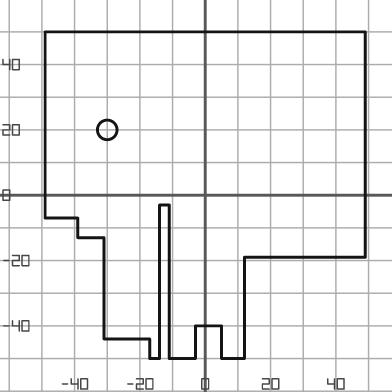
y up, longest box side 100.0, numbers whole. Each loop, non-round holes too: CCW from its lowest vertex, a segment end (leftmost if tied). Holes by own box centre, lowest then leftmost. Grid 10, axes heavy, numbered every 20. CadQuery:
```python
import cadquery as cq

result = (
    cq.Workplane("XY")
    .moveTo(-17.0, -50.0)
    .lineTo(-14.0, -50.0)
    .lineTo(-14.0, -3.0)
    .lineTo(-11.0, -3.0)
    .lineTo(-11.0, -50.0)
    .lineTo(-3.0, -50.0)
    .lineTo(-3.0, -40.0)
    .lineTo(5.0, -40.0)
    .lineTo(5.0, -50.0)
    .lineTo(12.0, -50.0)
    .lineTo(12.0, -19.0)
    .lineTo(49.0, -19.0)
    .lineTo(49.0, 50.0)
    .lineTo(-49.0, 50.0)
    .lineTo(-49.0, -7.0)
    .lineTo(-39.0, -7.0)
    .lineTo(-39.0, -13.0)
    .lineTo(-31.0, -13.0)
    .lineTo(-31.0, -44.0)
    .lineTo(-17.0, -44.0)
    .close()
    .moveTo(-30.0, 20.0)
    .circle(3.0)
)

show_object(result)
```